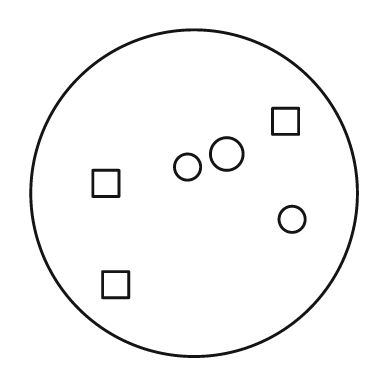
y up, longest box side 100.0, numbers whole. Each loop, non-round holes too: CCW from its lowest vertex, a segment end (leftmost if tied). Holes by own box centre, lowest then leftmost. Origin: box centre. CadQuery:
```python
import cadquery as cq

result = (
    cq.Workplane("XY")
    .moveTo(0.0, 0.0)
    .circle(50.0)
    .moveTo(-28.0, -32.0)
    .lineTo(-20.0, -32.0)
    .lineTo(-20.0, -24.0)
    .lineTo(-28.0, -24.0)
    .close()
    .moveTo(30.0, -8.0)
    .circle(4.0)
    .moveTo(-31.0, -1.0)
    .lineTo(-23.0, -1.0)
    .lineTo(-23.0, 7.0)
    .lineTo(-31.0, 7.0)
    .close()
    .moveTo(-2.0, 8.0)
    .circle(4.0)
    .moveTo(10.0, 12.0)
    .circle(5.0)
    .moveTo(24.0, 18.0)
    .lineTo(32.0, 18.0)
    .lineTo(32.0, 26.0)
    .lineTo(24.0, 26.0)
    .close()
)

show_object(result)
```